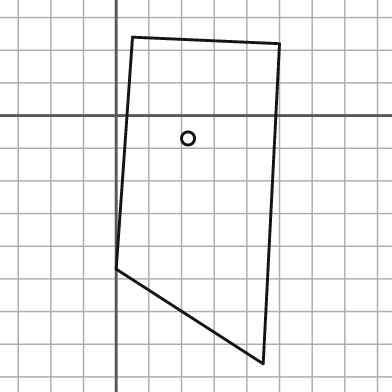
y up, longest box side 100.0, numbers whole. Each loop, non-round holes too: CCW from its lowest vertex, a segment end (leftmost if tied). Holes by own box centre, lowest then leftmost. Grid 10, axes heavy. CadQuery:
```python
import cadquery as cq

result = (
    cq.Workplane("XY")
    .moveTo(45.0, -76.0)
    .lineTo(50.0, 22.0)
    .lineTo(5.0, 24.0)
    .lineTo(0.0, -47.0)
    .close()
    .moveTo(22.0, -7.0)
    .circle(2.0)
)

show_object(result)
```